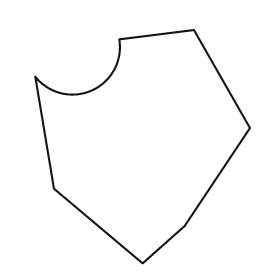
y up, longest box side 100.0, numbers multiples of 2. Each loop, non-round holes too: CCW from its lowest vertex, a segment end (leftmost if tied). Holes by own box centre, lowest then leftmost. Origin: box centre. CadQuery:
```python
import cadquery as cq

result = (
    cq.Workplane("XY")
    .moveTo(0.0, -50.0)
    .lineTo(18.0, -34.0)
    .lineTo(46.0, 8.0)
    .lineTo(22.0, 50.0)
    .lineTo(-10.0, 46.0)
    .threePointArc((-22.0, 24.0), (-46.0, 30.0))
    .lineTo(-38.0, -18.0)
    .close()
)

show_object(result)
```